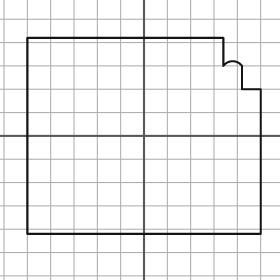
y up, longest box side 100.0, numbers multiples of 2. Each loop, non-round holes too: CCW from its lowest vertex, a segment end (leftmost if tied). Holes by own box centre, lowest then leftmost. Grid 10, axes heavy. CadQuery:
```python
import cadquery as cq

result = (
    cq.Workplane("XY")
    .moveTo(-50.0, -42.0)
    .lineTo(50.0, -42.0)
    .lineTo(50.0, 20.0)
    .lineTo(42.0, 20.0)
    .lineTo(42.0, 30.0)
    .threePointArc((38.0, 32.0), (34.0, 30.0))
    .lineTo(34.0, 42.0)
    .lineTo(-50.0, 42.0)
    .close()
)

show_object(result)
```